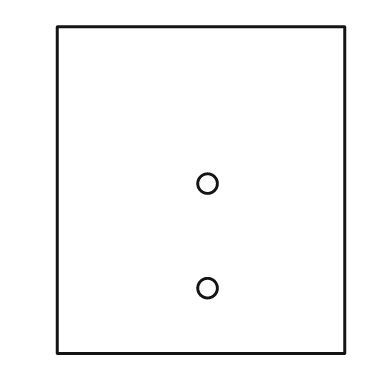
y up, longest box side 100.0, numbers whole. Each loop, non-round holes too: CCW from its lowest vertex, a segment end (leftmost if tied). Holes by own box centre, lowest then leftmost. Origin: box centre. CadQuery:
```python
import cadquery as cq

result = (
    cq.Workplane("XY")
    .moveTo(-44.0, -50.0)
    .lineTo(44.0, -50.0)
    .lineTo(44.0, 50.0)
    .lineTo(-44.0, 50.0)
    .close()
    .moveTo(2.0, -30.0)
    .circle(3.0)
    .moveTo(2.0, 2.0)
    .circle(3.0)
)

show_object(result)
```